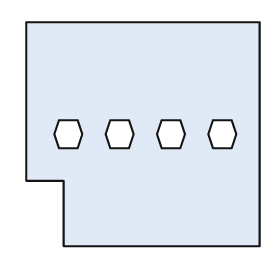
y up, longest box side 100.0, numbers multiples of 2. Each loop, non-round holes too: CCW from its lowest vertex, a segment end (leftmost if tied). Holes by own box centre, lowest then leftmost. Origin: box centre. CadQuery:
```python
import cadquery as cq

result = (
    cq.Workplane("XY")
    .moveTo(-34.0, -48.0)
    .lineTo(50.0, -48.0)
    .lineTo(50.0, 48.0)
    .lineTo(-50.0, 48.0)
    .lineTo(-50.0, -20.0)
    .lineTo(-34.0, -20.0)
    .close()
    .moveTo(-36.0, -6.0)
    .lineTo(-28.0, -6.0)
    .lineTo(-26.0, 0.0)
    .lineTo(-28.0, 6.0)
    .lineTo(-36.0, 6.0)
    .lineTo(-38.0, 0.0)
    .close()
    .moveTo(-14.0, -6.0)
    .lineTo(-6.0, -6.0)
    .lineTo(-4.0, 0.0)
    .lineTo(-6.0, 6.0)
    .lineTo(-14.0, 6.0)
    .lineTo(-16.0, 0.0)
    .close()
    .moveTo(8.0, -6.0)
    .lineTo(16.0, -6.0)
    .lineTo(18.0, 0.0)
    .lineTo(16.0, 6.0)
    .lineTo(8.0, 6.0)
    .lineTo(6.0, 0.0)
    .close()
    .moveTo(30.0, -6.0)
    .lineTo(38.0, -6.0)
    .lineTo(40.0, 0.0)
    .lineTo(38.0, 6.0)
    .lineTo(30.0, 6.0)
    .lineTo(28.0, 0.0)
    .close()
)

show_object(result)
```